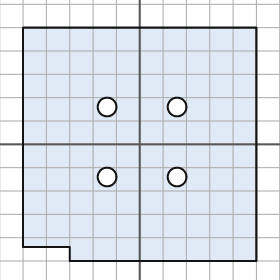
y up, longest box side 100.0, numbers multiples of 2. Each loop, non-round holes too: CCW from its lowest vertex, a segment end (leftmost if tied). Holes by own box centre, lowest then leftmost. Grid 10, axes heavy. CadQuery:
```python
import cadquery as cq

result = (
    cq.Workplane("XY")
    .moveTo(-30.0, -50.0)
    .lineTo(50.0, -50.0)
    .lineTo(50.0, 50.0)
    .lineTo(-50.0, 50.0)
    .lineTo(-50.0, -44.0)
    .lineTo(-30.0, -44.0)
    .close()
    .moveTo(-14.0, -14.0)
    .circle(4.0)
    .moveTo(16.0, -14.0)
    .circle(4.0)
    .moveTo(-14.0, 16.0)
    .circle(4.0)
    .moveTo(16.0, 16.0)
    .circle(4.0)
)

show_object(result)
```